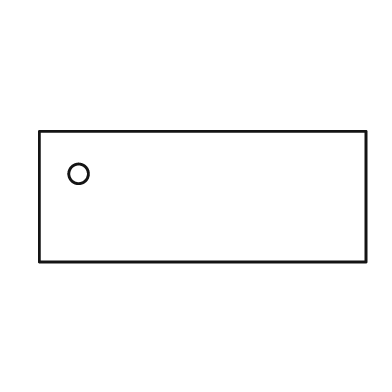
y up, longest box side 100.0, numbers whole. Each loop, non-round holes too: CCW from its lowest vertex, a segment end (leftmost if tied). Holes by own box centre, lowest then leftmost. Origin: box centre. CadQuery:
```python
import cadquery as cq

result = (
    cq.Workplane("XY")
    .moveTo(-50.0, -20.0)
    .lineTo(50.0, -20.0)
    .lineTo(50.0, 20.0)
    .lineTo(-50.0, 20.0)
    .close()
    .moveTo(-38.0, 7.0)
    .circle(3.0)
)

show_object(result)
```